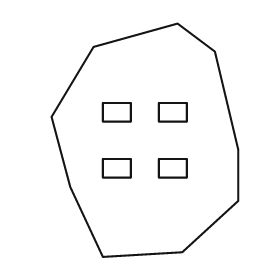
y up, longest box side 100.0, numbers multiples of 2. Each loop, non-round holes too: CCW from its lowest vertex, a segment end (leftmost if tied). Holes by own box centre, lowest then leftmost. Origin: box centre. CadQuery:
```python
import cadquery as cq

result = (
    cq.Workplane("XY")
    .moveTo(-18.0, -50.0)
    .lineTo(16.0, -48.0)
    .lineTo(40.0, -26.0)
    .lineTo(40.0, -4.0)
    .lineTo(30.0, 38.0)
    .lineTo(14.0, 50.0)
    .lineTo(-22.0, 40.0)
    .lineTo(-40.0, 10.0)
    .lineTo(-32.0, -20.0)
    .close()
    .moveTo(-18.0, -16.0)
    .lineTo(-6.0, -16.0)
    .lineTo(-6.0, -8.0)
    .lineTo(-18.0, -8.0)
    .close()
    .moveTo(6.0, -16.0)
    .lineTo(18.0, -16.0)
    .lineTo(18.0, -8.0)
    .lineTo(6.0, -8.0)
    .close()
    .moveTo(-18.0, 8.0)
    .lineTo(-6.0, 8.0)
    .lineTo(-6.0, 16.0)
    .lineTo(-18.0, 16.0)
    .close()
    .moveTo(6.0, 8.0)
    .lineTo(18.0, 8.0)
    .lineTo(18.0, 16.0)
    .lineTo(6.0, 16.0)
    .close()
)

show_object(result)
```